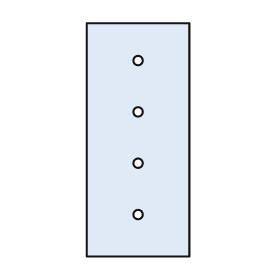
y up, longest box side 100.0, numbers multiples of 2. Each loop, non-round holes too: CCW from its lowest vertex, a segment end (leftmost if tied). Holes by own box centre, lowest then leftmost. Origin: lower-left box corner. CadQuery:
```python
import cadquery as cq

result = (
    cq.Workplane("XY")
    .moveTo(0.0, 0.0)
    .lineTo(44.0, 0.0)
    .lineTo(44.0, 100.0)
    .lineTo(0.0, 100.0)
    .close()
    .moveTo(22.0, 18.0)
    .circle(2.0)
    .moveTo(22.0, 40.0)
    .circle(2.0)
    .moveTo(22.0, 62.0)
    .circle(2.0)
    .moveTo(22.0, 84.0)
    .circle(2.0)
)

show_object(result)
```